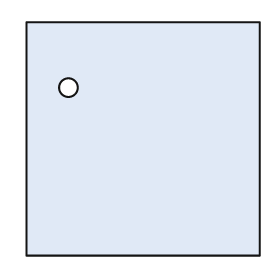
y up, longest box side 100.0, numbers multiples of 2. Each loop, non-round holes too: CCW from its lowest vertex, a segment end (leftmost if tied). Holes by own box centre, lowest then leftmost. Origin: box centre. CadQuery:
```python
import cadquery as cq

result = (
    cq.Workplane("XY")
    .moveTo(-50.0, -50.0)
    .lineTo(50.0, -50.0)
    .lineTo(50.0, 50.0)
    .lineTo(-50.0, 50.0)
    .close()
    .moveTo(-32.0, 22.0)
    .circle(4.0)
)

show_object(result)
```